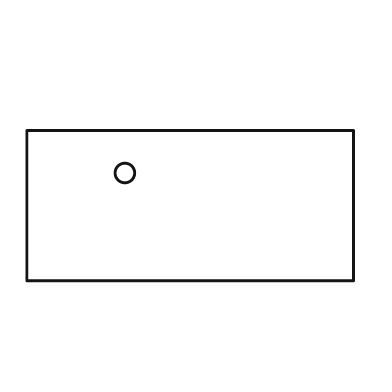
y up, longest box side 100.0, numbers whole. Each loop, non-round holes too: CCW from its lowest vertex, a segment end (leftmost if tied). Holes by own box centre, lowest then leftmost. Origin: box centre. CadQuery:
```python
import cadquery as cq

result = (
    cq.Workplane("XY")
    .moveTo(-50.0, -23.0)
    .lineTo(50.0, -23.0)
    .lineTo(50.0, 23.0)
    .lineTo(-50.0, 23.0)
    .close()
    .moveTo(-20.0, 10.0)
    .circle(3.0)
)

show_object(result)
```